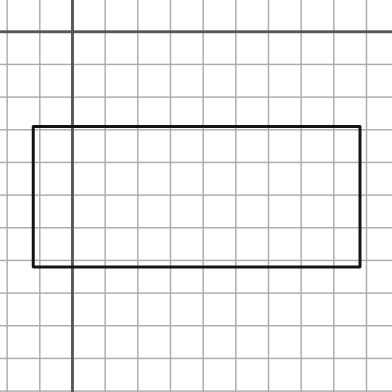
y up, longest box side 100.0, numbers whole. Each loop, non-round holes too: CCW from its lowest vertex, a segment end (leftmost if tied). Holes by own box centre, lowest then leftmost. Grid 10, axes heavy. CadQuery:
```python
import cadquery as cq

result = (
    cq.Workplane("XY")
    .moveTo(-12.0, -72.0)
    .lineTo(88.0, -72.0)
    .lineTo(88.0, -29.0)
    .lineTo(-12.0, -29.0)
    .close()
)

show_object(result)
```